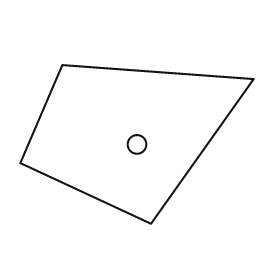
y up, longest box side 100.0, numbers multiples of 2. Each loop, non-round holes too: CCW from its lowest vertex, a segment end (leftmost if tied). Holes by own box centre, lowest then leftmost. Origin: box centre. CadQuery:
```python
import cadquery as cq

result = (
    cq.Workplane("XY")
    .moveTo(6.0, -34.0)
    .lineTo(50.0, 28.0)
    .lineTo(-32.0, 34.0)
    .lineTo(-50.0, -8.0)
    .close()
    .moveTo(0.0, 0.0)
    .circle(4.0)
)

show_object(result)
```